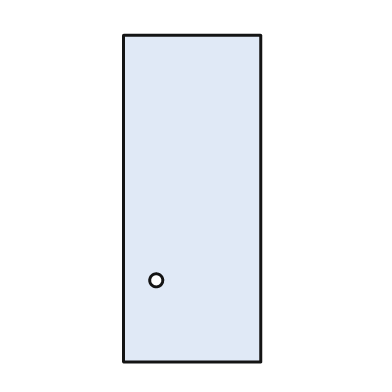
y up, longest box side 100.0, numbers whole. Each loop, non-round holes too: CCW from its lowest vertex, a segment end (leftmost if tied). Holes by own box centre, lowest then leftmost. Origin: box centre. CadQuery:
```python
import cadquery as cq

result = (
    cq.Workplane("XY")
    .moveTo(-21.0, -50.0)
    .lineTo(21.0, -50.0)
    .lineTo(21.0, 50.0)
    .lineTo(-21.0, 50.0)
    .close()
    .moveTo(-11.0, -25.0)
    .circle(2.0)
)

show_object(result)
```